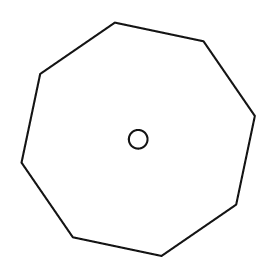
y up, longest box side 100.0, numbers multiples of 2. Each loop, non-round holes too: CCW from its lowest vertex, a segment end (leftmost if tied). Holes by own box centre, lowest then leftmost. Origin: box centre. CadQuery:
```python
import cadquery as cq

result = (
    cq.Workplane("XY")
    .moveTo(10.0, -50.0)
    .lineTo(42.0, -28.0)
    .lineTo(50.0, 10.0)
    .lineTo(28.0, 42.0)
    .lineTo(-10.0, 50.0)
    .lineTo(-42.0, 28.0)
    .lineTo(-50.0, -10.0)
    .lineTo(-28.0, -42.0)
    .close()
    .moveTo(0.0, 0.0)
    .circle(4.0)
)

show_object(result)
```